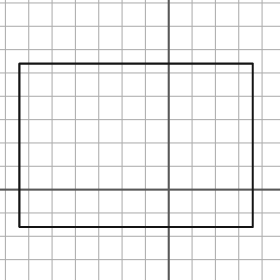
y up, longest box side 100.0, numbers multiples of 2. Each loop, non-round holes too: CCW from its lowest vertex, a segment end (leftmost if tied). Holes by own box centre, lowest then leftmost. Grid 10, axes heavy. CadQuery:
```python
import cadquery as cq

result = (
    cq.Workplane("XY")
    .moveTo(-64.0, -16.0)
    .lineTo(36.0, -16.0)
    .lineTo(36.0, 54.0)
    .lineTo(-64.0, 54.0)
    .close()
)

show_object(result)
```